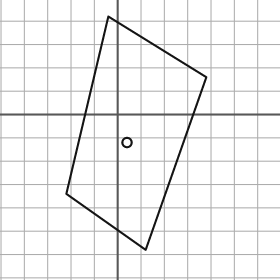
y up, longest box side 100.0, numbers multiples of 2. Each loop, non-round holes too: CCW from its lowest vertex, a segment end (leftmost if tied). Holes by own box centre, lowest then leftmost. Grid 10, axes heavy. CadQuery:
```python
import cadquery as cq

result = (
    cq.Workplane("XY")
    .moveTo(12.0, -58.0)
    .lineTo(38.0, 16.0)
    .lineTo(-4.0, 42.0)
    .lineTo(-22.0, -34.0)
    .close()
    .moveTo(4.0, -12.0)
    .circle(2.0)
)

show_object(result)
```